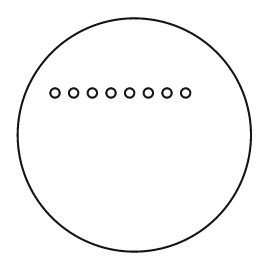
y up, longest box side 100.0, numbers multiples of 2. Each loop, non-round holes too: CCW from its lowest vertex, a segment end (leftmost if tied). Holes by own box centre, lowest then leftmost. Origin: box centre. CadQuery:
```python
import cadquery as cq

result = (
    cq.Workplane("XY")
    .moveTo(0.0, 0.0)
    .circle(50.0)
    .moveTo(-34.0, 18.0)
    .circle(2.0)
    .moveTo(-26.0, 18.0)
    .circle(2.0)
    .moveTo(-18.0, 18.0)
    .circle(2.0)
    .moveTo(-10.0, 18.0)
    .circle(2.0)
    .moveTo(-2.0, 18.0)
    .circle(2.0)
    .moveTo(6.0, 18.0)
    .circle(2.0)
    .moveTo(14.0, 18.0)
    .circle(2.0)
    .moveTo(22.0, 18.0)
    .circle(2.0)
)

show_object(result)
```